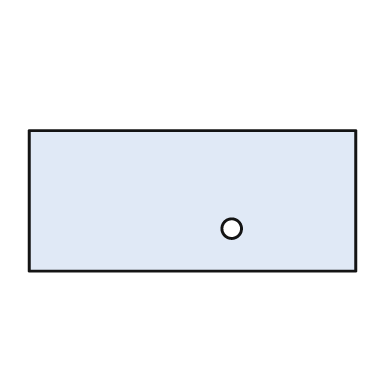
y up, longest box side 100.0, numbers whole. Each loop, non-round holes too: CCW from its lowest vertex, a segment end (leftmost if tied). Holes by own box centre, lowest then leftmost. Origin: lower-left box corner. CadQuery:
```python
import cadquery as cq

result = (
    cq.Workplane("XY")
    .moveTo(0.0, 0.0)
    .lineTo(100.0, 0.0)
    .lineTo(100.0, 43.0)
    .lineTo(0.0, 43.0)
    .close()
    .moveTo(62.0, 13.0)
    .circle(3.0)
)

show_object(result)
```